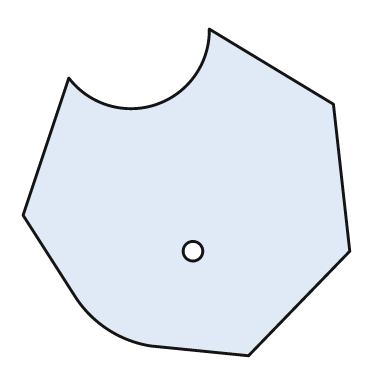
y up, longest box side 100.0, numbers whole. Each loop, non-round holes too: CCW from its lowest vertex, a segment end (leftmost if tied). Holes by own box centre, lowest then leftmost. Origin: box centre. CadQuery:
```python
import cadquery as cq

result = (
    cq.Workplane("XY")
    .moveTo(19.0, -50.0)
    .lineTo(50.0, -18.0)
    .lineTo(45.0, 27.0)
    .lineTo(7.0, 50.0)
    .threePointArc((-9.0, 27.0), (-36.0, 35.0))
    .lineTo(-50.0, -7.0)
    .lineTo(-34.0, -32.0)
    .threePointArc((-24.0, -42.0), (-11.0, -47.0))
    .close()
    .moveTo(2.0, -18.0)
    .circle(3.0)
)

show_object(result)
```